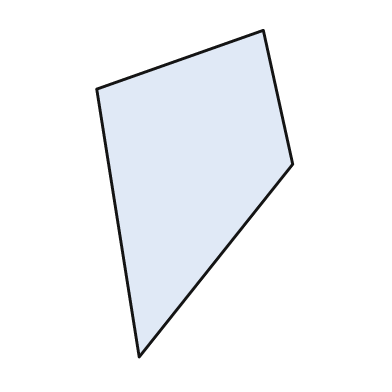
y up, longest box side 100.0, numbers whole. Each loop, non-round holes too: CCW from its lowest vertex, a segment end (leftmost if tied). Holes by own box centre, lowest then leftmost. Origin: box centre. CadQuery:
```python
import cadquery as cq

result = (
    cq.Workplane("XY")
    .moveTo(-17.0, -50.0)
    .lineTo(30.0, 9.0)
    .lineTo(21.0, 50.0)
    .lineTo(-30.0, 32.0)
    .close()
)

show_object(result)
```